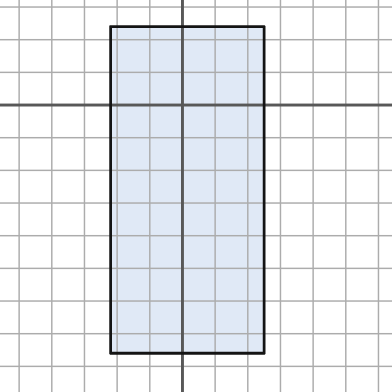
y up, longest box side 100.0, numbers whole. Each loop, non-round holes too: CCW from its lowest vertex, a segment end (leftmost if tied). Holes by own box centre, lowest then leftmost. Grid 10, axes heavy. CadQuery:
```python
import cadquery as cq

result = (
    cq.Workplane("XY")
    .moveTo(-22.0, -76.0)
    .lineTo(25.0, -76.0)
    .lineTo(25.0, 24.0)
    .lineTo(-22.0, 24.0)
    .close()
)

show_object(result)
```